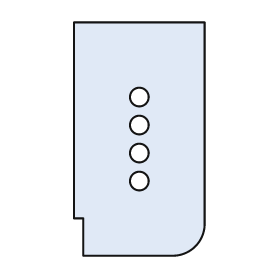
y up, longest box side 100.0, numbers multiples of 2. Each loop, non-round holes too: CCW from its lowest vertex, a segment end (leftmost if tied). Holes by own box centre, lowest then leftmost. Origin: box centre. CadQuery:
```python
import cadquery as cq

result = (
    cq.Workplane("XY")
    .moveTo(-24.0, -50.0)
    .lineTo(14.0, -50.0)
    .threePointArc((24.0, -46.0), (28.0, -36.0))
    .lineTo(28.0, 50.0)
    .lineTo(-28.0, 50.0)
    .lineTo(-28.0, -34.0)
    .lineTo(-24.0, -34.0)
    .close()
    .moveTo(0.0, -18.0)
    .circle(4.0)
    .moveTo(0.0, -6.0)
    .circle(4.0)
    .moveTo(0.0, 6.0)
    .circle(4.0)
    .moveTo(0.0, 18.0)
    .circle(4.0)
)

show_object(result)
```